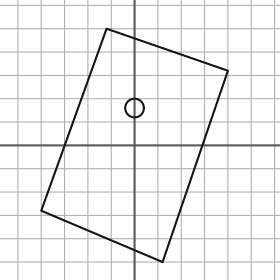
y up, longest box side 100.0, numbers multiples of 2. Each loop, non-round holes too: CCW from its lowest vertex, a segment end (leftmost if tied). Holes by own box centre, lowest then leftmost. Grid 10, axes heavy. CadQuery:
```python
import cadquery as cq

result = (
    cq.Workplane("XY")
    .moveTo(12.0, -50.0)
    .lineTo(40.0, 32.0)
    .lineTo(-12.0, 50.0)
    .lineTo(-40.0, -28.0)
    .close()
    .moveTo(0.0, 16.0)
    .circle(4.0)
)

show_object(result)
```